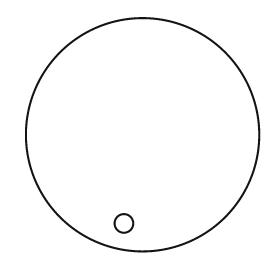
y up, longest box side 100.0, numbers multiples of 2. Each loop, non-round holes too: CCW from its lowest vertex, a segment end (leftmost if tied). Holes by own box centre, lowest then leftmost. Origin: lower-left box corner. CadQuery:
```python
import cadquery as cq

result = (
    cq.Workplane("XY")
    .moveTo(50.0, 50.0)
    .circle(50.0)
    .moveTo(42.0, 12.0)
    .circle(4.0)
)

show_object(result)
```